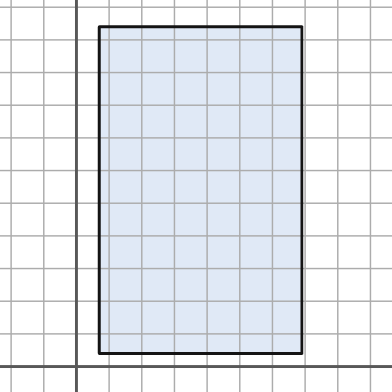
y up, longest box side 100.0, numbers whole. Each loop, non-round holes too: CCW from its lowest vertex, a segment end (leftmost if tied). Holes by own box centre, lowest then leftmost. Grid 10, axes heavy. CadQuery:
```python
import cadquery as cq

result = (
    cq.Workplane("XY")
    .moveTo(7.0, 4.0)
    .lineTo(69.0, 4.0)
    .lineTo(69.0, 104.0)
    .lineTo(7.0, 104.0)
    .close()
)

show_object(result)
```